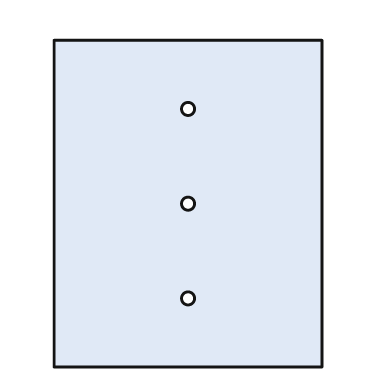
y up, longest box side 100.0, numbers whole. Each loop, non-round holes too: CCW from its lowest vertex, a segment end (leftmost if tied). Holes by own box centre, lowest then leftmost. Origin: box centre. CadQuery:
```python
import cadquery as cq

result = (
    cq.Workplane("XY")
    .moveTo(-41.0, -50.0)
    .lineTo(41.0, -50.0)
    .lineTo(41.0, 50.0)
    .lineTo(-41.0, 50.0)
    .close()
    .moveTo(0.0, -29.0)
    .circle(2.0)
    .moveTo(0.0, 0.0)
    .circle(2.0)
    .moveTo(0.0, 29.0)
    .circle(2.0)
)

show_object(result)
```